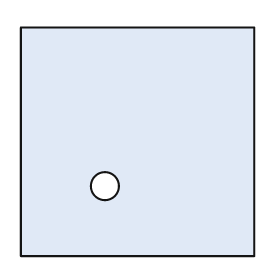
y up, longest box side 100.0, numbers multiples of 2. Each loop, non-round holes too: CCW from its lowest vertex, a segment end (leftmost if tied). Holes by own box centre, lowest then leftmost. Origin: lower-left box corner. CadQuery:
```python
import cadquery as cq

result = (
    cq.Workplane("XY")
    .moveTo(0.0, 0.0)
    .lineTo(100.0, 0.0)
    .lineTo(100.0, 98.0)
    .lineTo(0.0, 98.0)
    .close()
    .moveTo(36.0, 30.0)
    .circle(6.0)
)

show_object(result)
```